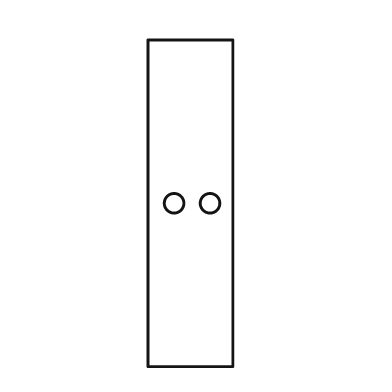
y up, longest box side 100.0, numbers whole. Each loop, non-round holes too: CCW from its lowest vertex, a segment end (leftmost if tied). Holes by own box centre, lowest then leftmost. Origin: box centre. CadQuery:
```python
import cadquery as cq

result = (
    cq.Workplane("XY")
    .moveTo(-13.0, -50.0)
    .lineTo(13.0, -50.0)
    .lineTo(13.0, 50.0)
    .lineTo(-13.0, 50.0)
    .close()
    .moveTo(-5.0, 0.0)
    .circle(3.0)
    .moveTo(6.0, 0.0)
    .circle(3.0)
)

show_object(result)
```